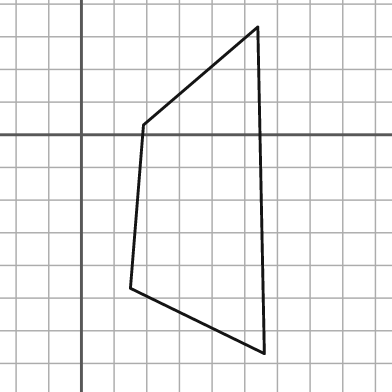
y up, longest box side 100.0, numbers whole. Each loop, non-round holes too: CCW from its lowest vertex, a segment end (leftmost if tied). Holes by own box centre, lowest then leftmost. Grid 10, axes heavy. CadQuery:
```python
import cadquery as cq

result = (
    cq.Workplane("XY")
    .moveTo(56.0, -67.0)
    .lineTo(54.0, 33.0)
    .lineTo(19.0, 3.0)
    .lineTo(15.0, -47.0)
    .close()
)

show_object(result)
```